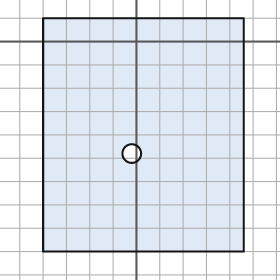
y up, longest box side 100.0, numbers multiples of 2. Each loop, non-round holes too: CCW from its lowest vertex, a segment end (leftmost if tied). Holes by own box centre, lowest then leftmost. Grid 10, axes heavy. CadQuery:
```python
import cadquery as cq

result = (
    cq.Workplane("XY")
    .moveTo(-40.0, -90.0)
    .lineTo(46.0, -90.0)
    .lineTo(46.0, 10.0)
    .lineTo(-40.0, 10.0)
    .close()
    .moveTo(-2.0, -48.0)
    .circle(4.0)
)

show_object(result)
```